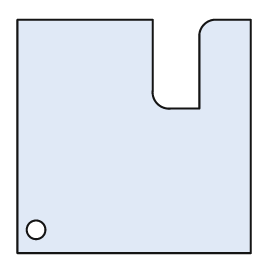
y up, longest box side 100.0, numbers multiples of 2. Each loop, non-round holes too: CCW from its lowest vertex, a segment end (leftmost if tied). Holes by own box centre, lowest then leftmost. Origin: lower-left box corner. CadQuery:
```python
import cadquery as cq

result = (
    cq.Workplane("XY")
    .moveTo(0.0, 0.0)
    .lineTo(100.0, 0.0)
    .lineTo(100.0, 100.0)
    .lineTo(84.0, 100.0)
    .threePointArc((80.0, 98.0), (78.0, 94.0))
    .lineTo(78.0, 62.0)
    .lineTo(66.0, 62.0)
    .threePointArc((60.0, 64.0), (58.0, 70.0))
    .lineTo(58.0, 100.0)
    .lineTo(0.0, 100.0)
    .close()
    .moveTo(8.0, 10.0)
    .circle(4.0)
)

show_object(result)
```